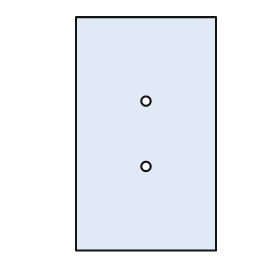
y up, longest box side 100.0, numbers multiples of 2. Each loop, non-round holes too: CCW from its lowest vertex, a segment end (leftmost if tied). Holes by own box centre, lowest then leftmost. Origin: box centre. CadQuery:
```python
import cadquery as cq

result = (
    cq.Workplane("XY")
    .moveTo(-30.0, -50.0)
    .lineTo(30.0, -50.0)
    .lineTo(30.0, 50.0)
    .lineTo(-30.0, 50.0)
    .close()
    .moveTo(0.0, -14.0)
    .circle(2.0)
    .moveTo(0.0, 14.0)
    .circle(2.0)
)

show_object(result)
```